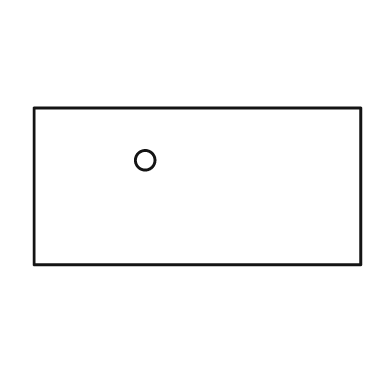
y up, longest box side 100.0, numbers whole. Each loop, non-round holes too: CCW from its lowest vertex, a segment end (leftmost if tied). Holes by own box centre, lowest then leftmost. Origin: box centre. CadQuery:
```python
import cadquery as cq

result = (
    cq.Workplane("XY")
    .moveTo(-50.0, -24.0)
    .lineTo(50.0, -24.0)
    .lineTo(50.0, 24.0)
    .lineTo(-50.0, 24.0)
    .close()
    .moveTo(-16.0, 8.0)
    .circle(3.0)
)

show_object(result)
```